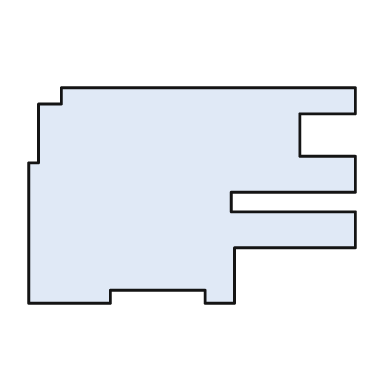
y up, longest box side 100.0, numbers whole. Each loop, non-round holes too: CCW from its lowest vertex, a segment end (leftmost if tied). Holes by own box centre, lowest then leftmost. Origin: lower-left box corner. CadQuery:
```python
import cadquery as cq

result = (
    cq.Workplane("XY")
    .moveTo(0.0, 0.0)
    .lineTo(25.0, 0.0)
    .lineTo(25.0, 4.0)
    .lineTo(54.0, 4.0)
    .lineTo(54.0, 0.0)
    .lineTo(63.0, 0.0)
    .lineTo(63.0, 17.0)
    .lineTo(100.0, 17.0)
    .lineTo(100.0, 28.0)
    .lineTo(62.0, 28.0)
    .lineTo(62.0, 34.0)
    .lineTo(100.0, 34.0)
    .lineTo(100.0, 45.0)
    .lineTo(83.0, 45.0)
    .lineTo(83.0, 58.0)
    .lineTo(100.0, 58.0)
    .lineTo(100.0, 66.0)
    .lineTo(10.0, 66.0)
    .lineTo(10.0, 61.0)
    .lineTo(3.0, 61.0)
    .lineTo(3.0, 43.0)
    .lineTo(0.0, 43.0)
    .close()
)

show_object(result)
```